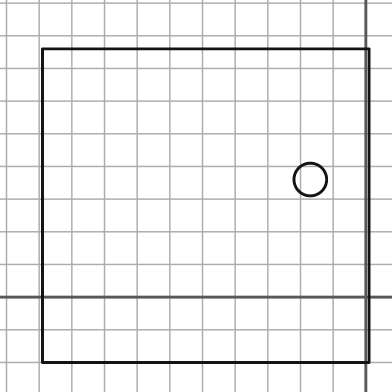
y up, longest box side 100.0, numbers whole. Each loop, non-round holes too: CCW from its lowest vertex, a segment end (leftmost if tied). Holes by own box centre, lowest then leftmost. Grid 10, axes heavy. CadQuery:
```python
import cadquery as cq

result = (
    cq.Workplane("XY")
    .moveTo(-99.0, -20.0)
    .lineTo(1.0, -20.0)
    .lineTo(1.0, 76.0)
    .lineTo(-99.0, 76.0)
    .close()
    .moveTo(-17.0, 36.0)
    .circle(5.0)
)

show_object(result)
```